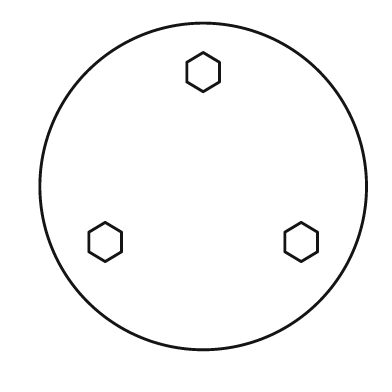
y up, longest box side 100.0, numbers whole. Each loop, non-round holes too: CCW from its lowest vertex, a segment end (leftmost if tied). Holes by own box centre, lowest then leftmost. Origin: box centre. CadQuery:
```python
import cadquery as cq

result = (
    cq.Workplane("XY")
    .moveTo(0.0, 0.0)
    .circle(50.0)
    .moveTo(-30.0, -23.0)
    .lineTo(-25.0, -20.0)
    .lineTo(-25.0, -14.0)
    .lineTo(-30.0, -11.0)
    .lineTo(-35.0, -14.0)
    .lineTo(-35.0, -20.0)
    .close()
    .moveTo(30.0, -23.0)
    .lineTo(35.0, -20.0)
    .lineTo(35.0, -14.0)
    .lineTo(30.0, -11.0)
    .lineTo(25.0, -14.0)
    .lineTo(25.0, -20.0)
    .close()
    .moveTo(0.0, 29.0)
    .lineTo(5.0, 32.0)
    .lineTo(5.0, 38.0)
    .lineTo(0.0, 41.0)
    .lineTo(-5.0, 38.0)
    .lineTo(-5.0, 32.0)
    .close()
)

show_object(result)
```